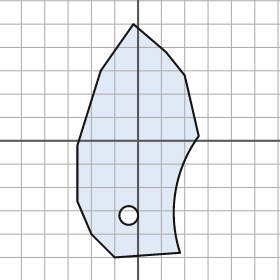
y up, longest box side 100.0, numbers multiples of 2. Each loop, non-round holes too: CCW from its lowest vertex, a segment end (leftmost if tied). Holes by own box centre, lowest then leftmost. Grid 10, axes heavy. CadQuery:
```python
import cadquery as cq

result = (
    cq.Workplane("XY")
    .moveTo(-10.0, -50.0)
    .lineTo(18.0, -48.0)
    .threePointArc((16.0, -22.0), (26.0, 2.0))
    .lineTo(20.0, 28.0)
    .lineTo(12.0, 38.0)
    .lineTo(-2.0, 50.0)
    .lineTo(-16.0, 30.0)
    .lineTo(-26.0, -2.0)
    .lineTo(-26.0, -26.0)
    .lineTo(-20.0, -40.0)
    .close()
    .moveTo(-4.0, -32.0)
    .circle(4.0)
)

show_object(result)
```